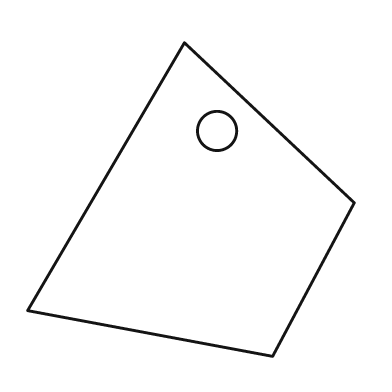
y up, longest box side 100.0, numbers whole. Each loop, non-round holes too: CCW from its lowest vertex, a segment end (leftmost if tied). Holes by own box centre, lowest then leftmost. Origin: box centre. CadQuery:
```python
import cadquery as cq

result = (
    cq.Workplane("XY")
    .moveTo(25.0, -48.0)
    .lineTo(50.0, -1.0)
    .lineTo(-2.0, 48.0)
    .lineTo(-50.0, -34.0)
    .close()
    .moveTo(8.0, 21.0)
    .circle(6.0)
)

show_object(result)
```